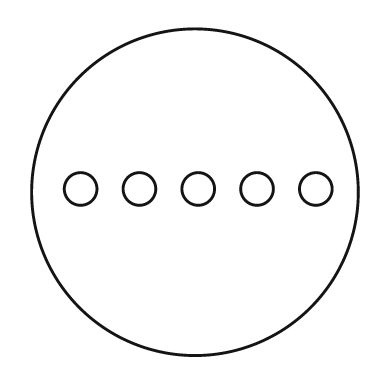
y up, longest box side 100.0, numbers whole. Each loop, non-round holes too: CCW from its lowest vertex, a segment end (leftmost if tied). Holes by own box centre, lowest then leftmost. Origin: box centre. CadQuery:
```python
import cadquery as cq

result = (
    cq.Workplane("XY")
    .moveTo(0.0, 0.0)
    .circle(50.0)
    .moveTo(-35.0, 1.0)
    .circle(5.0)
    .moveTo(-17.0, 1.0)
    .circle(5.0)
    .moveTo(1.0, 1.0)
    .circle(5.0)
    .moveTo(19.0, 1.0)
    .circle(5.0)
    .moveTo(37.0, 1.0)
    .circle(5.0)
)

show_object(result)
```